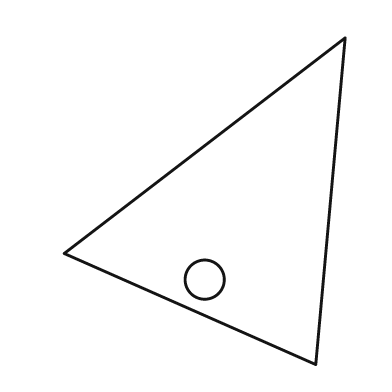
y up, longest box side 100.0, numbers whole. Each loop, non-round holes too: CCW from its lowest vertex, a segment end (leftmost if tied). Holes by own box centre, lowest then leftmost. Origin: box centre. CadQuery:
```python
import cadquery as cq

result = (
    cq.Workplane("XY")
    .moveTo(34.0, -50.0)
    .lineTo(43.0, 50.0)
    .lineTo(-43.0, -16.0)
    .close()
    .moveTo(0.0, -24.0)
    .circle(6.0)
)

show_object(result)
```